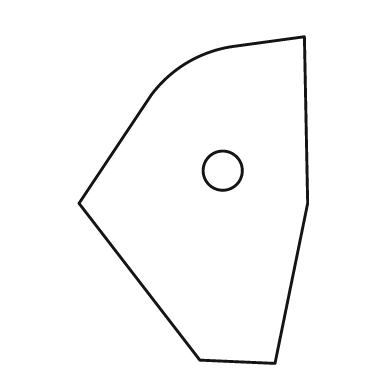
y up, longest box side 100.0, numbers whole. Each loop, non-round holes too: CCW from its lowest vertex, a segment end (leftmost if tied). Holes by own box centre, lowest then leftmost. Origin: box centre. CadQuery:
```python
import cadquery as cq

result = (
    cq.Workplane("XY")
    .moveTo(25.0, -50.0)
    .lineTo(35.0, -1.0)
    .lineTo(34.0, 50.0)
    .lineTo(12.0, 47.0)
    .threePointArc((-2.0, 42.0), (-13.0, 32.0))
    .lineTo(-35.0, -1.0)
    .lineTo(2.0, -49.0)
    .close()
    .moveTo(9.0, 9.0)
    .circle(6.0)
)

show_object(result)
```